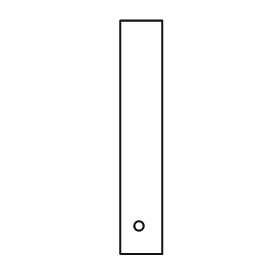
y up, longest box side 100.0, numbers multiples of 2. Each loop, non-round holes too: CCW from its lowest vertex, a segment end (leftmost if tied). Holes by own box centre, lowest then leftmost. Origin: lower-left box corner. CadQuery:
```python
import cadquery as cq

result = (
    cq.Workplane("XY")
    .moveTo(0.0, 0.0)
    .lineTo(18.0, 0.0)
    .lineTo(18.0, 100.0)
    .lineTo(0.0, 100.0)
    .close()
    .moveTo(8.0, 12.0)
    .circle(2.0)
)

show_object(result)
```